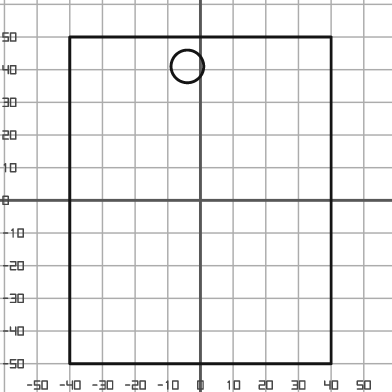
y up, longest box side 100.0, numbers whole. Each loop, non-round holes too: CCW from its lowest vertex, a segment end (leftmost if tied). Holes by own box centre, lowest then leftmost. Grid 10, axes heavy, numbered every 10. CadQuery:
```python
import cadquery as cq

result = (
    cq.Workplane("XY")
    .moveTo(-40.0, -50.0)
    .lineTo(40.0, -50.0)
    .lineTo(40.0, 50.0)
    .lineTo(-40.0, 50.0)
    .close()
    .moveTo(-4.0, 41.0)
    .circle(5.0)
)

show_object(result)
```